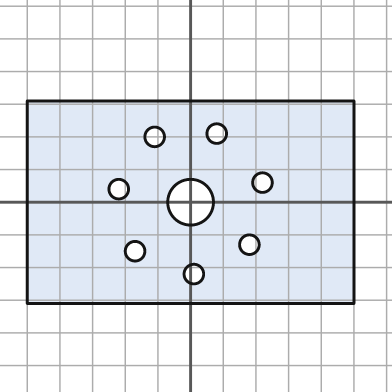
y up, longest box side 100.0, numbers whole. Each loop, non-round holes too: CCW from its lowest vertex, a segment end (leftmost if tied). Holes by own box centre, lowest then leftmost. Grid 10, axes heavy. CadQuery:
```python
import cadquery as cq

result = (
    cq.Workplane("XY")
    .moveTo(-50.0, -31.0)
    .lineTo(50.0, -31.0)
    .lineTo(50.0, 31.0)
    .lineTo(-50.0, 31.0)
    .close()
    .moveTo(1.0, -22.0)
    .circle(3.0)
    .moveTo(-17.0, -15.0)
    .circle(3.0)
    .moveTo(18.0, -13.0)
    .circle(3.0)
    .moveTo(0.0, 0.0)
    .circle(7.0)
    .moveTo(-22.0, 4.0)
    .circle(3.0)
    .moveTo(22.0, 6.0)
    .circle(3.0)
    .moveTo(-11.0, 20.0)
    .circle(3.0)
    .moveTo(8.0, 21.0)
    .circle(3.0)
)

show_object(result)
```